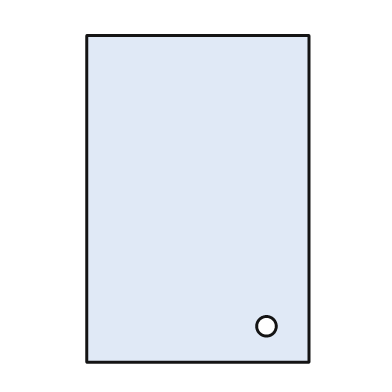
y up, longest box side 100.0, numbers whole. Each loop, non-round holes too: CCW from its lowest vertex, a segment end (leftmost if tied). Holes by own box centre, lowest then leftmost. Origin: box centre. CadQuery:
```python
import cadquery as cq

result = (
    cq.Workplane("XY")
    .moveTo(-34.0, -50.0)
    .lineTo(34.0, -50.0)
    .lineTo(34.0, 50.0)
    .lineTo(-34.0, 50.0)
    .close()
    .moveTo(21.0, -39.0)
    .circle(3.0)
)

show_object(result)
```